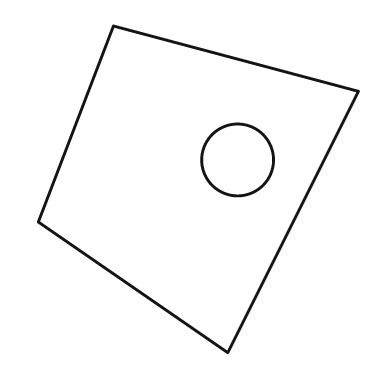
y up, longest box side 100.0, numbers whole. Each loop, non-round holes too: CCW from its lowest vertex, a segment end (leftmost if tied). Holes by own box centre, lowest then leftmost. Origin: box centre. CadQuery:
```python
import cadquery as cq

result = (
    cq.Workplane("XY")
    .moveTo(9.0, -50.0)
    .lineTo(49.0, 30.0)
    .lineTo(-26.0, 50.0)
    .lineTo(-49.0, -10.0)
    .close()
    .moveTo(12.0, 9.0)
    .circle(11.0)
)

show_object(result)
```